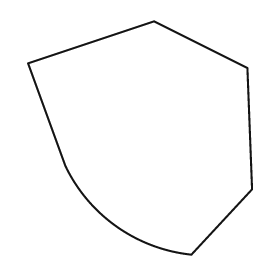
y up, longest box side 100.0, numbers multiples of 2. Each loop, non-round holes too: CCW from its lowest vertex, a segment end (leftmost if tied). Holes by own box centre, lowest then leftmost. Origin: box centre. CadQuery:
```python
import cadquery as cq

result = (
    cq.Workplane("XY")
    .moveTo(22.0, -50.0)
    .lineTo(48.0, -22.0)
    .lineTo(46.0, 30.0)
    .lineTo(6.0, 50.0)
    .lineTo(-48.0, 32.0)
    .lineTo(-32.0, -12.0)
    .threePointArc((-10.0, -38.0), (22.0, -50.0))
    .close()
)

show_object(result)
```